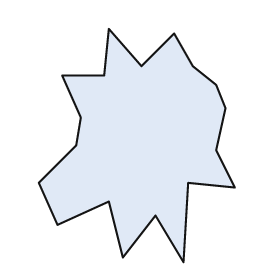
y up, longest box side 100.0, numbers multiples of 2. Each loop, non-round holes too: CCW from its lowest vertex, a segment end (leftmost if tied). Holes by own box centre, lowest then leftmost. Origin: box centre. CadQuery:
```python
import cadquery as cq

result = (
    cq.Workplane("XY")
    .moveTo(20.0, -50.0)
    .lineTo(22.0, -16.0)
    .lineTo(42.0, -18.0)
    .lineTo(34.0, -2.0)
    .lineTo(38.0, 16.0)
    .lineTo(34.0, 26.0)
    .lineTo(24.0, 34.0)
    .lineTo(16.0, 48.0)
    .lineTo(2.0, 34.0)
    .lineTo(-12.0, 50.0)
    .lineTo(-14.0, 30.0)
    .lineTo(-32.0, 30.0)
    .lineTo(-24.0, 12.0)
    .lineTo(-26.0, 0.0)
    .lineTo(-42.0, -16.0)
    .lineTo(-34.0, -34.0)
    .lineTo(-12.0, -24.0)
    .lineTo(-6.0, -48.0)
    .lineTo(8.0, -30.0)
    .close()
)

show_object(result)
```